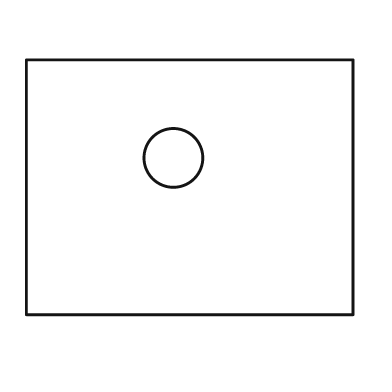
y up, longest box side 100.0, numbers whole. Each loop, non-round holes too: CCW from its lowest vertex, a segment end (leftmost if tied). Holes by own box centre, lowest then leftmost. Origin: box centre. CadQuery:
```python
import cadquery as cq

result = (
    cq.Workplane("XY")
    .moveTo(-50.0, -39.0)
    .lineTo(50.0, -39.0)
    .lineTo(50.0, 39.0)
    .lineTo(-50.0, 39.0)
    .close()
    .moveTo(-5.0, 9.0)
    .circle(9.0)
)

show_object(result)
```